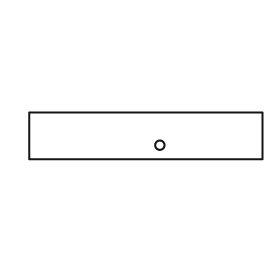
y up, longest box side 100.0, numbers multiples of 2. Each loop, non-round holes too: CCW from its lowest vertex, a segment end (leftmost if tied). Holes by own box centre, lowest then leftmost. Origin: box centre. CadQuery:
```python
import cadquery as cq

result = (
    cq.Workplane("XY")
    .moveTo(-50.0, -10.0)
    .lineTo(50.0, -10.0)
    .lineTo(50.0, 10.0)
    .lineTo(-50.0, 10.0)
    .close()
    .moveTo(6.0, -4.0)
    .circle(2.0)
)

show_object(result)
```